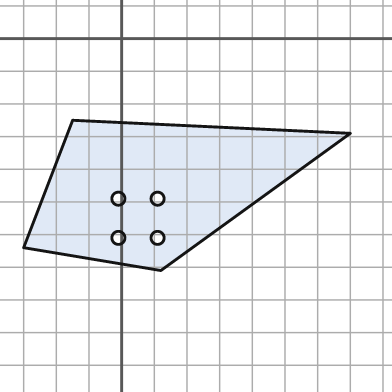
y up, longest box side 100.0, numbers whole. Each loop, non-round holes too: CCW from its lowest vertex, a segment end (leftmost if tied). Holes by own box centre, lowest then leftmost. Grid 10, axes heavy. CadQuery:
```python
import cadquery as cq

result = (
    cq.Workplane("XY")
    .moveTo(12.0, -71.0)
    .lineTo(70.0, -29.0)
    .lineTo(-15.0, -25.0)
    .lineTo(-30.0, -64.0)
    .close()
    .moveTo(-1.0, -61.0)
    .circle(2.0)
    .moveTo(11.0, -61.0)
    .circle(2.0)
    .moveTo(-1.0, -49.0)
    .circle(2.0)
    .moveTo(11.0, -49.0)
    .circle(2.0)
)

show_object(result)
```